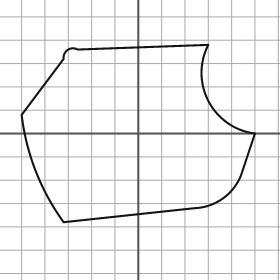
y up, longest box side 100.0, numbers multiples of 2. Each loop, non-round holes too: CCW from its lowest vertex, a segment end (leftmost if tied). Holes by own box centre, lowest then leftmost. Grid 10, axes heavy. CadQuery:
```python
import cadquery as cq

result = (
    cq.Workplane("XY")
    .moveTo(-32.0, -38.0)
    .lineTo(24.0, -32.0)
    .threePointArc((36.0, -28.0), (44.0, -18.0))
    .lineTo(50.0, 0.0)
    .threePointArc((30.0, 14.0), (30.0, 38.0))
    .lineTo(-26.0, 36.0)
    .threePointArc((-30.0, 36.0), (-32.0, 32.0))
    .lineTo(-50.0, 8.0)
    .threePointArc((-44.0, -16.0), (-32.0, -38.0))
    .close()
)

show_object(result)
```